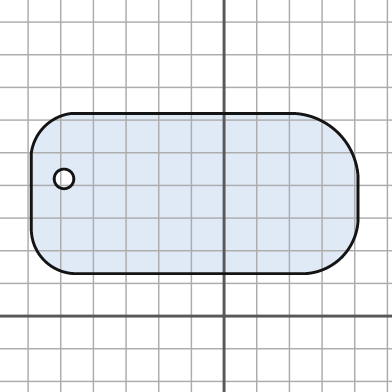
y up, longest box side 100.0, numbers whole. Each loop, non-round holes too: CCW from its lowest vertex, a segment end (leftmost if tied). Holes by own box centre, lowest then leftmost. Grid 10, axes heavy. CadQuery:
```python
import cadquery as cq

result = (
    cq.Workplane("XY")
    .moveTo(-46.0, 13.0)
    .lineTo(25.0, 13.0)
    .threePointArc((36.0, 18.0), (41.0, 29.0))
    .lineTo(41.0, 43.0)
    .threePointArc((35.0, 56.0), (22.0, 62.0))
    .lineTo(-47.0, 62.0)
    .threePointArc((-55.0, 58.0), (-59.0, 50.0))
    .lineTo(-59.0, 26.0)
    .threePointArc((-55.0, 17.0), (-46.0, 13.0))
    .close()
    .moveTo(-49.0, 42.0)
    .circle(3.0)
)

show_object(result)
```